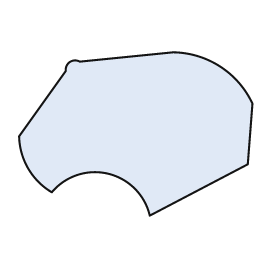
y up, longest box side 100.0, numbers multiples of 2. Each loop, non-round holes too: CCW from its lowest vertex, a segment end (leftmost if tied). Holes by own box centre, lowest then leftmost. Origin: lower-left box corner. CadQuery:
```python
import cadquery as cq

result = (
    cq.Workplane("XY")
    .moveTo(56.0, 0.0)
    .lineTo(98.0, 22.0)
    .lineTo(100.0, 48.0)
    .threePointArc((86.0, 64.0), (66.0, 70.0))
    .lineTo(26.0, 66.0)
    .threePointArc((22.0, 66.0), (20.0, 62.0))
    .lineTo(0.0, 34.0)
    .threePointArc((4.0, 20.0), (14.0, 10.0))
    .threePointArc((38.0, 18.0), (56.0, 0.0))
    .close()
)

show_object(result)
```